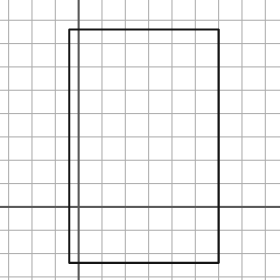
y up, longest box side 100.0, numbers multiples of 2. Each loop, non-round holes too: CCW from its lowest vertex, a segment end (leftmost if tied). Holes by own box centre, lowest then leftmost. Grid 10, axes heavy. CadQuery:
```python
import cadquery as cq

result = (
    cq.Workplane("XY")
    .moveTo(-4.0, -24.0)
    .lineTo(60.0, -24.0)
    .lineTo(60.0, 76.0)
    .lineTo(-4.0, 76.0)
    .close()
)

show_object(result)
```